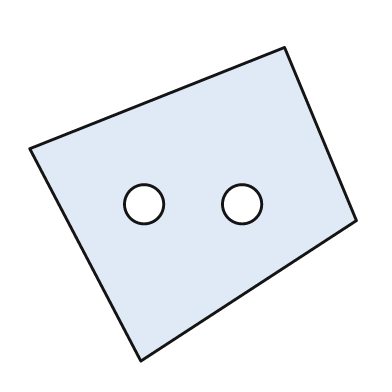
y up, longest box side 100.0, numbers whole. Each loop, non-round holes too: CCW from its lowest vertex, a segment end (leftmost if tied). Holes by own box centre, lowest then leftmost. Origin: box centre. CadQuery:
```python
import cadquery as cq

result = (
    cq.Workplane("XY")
    .moveTo(-16.0, -48.0)
    .lineTo(50.0, -5.0)
    .lineTo(28.0, 48.0)
    .lineTo(-50.0, 17.0)
    .close()
    .moveTo(-15.0, 0.0)
    .circle(6.0)
    .moveTo(15.0, 0.0)
    .circle(6.0)
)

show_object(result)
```